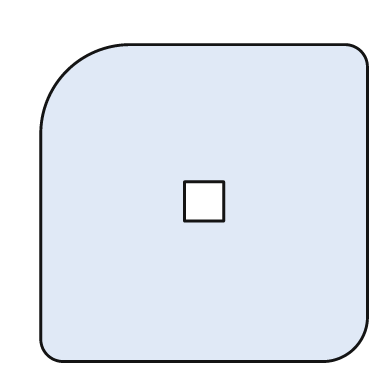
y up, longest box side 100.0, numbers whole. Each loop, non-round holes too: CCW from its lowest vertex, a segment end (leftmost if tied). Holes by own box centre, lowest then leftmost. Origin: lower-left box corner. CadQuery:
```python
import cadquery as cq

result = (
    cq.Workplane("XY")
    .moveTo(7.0, 0.0)
    .lineTo(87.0, 0.0)
    .threePointArc((96.0, 4.0), (100.0, 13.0))
    .lineTo(100.0, 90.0)
    .threePointArc((98.0, 95.0), (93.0, 97.0))
    .lineTo(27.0, 97.0)
    .threePointArc((8.0, 89.0), (0.0, 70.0))
    .lineTo(0.0, 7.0)
    .threePointArc((2.0, 2.0), (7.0, 0.0))
    .close()
    .moveTo(44.0, 43.0)
    .lineTo(56.0, 43.0)
    .lineTo(56.0, 55.0)
    .lineTo(44.0, 55.0)
    .close()
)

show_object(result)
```